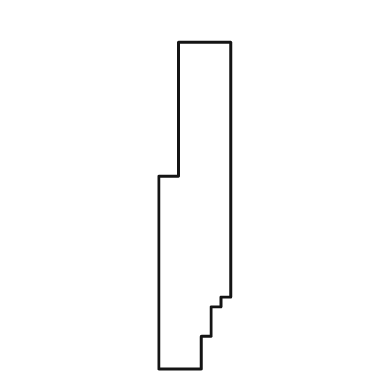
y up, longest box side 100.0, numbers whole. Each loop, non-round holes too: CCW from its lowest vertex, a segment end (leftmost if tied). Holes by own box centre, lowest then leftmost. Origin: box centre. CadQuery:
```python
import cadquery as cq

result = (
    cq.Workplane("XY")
    .moveTo(-11.0, -50.0)
    .lineTo(2.0, -50.0)
    .lineTo(2.0, -40.0)
    .lineTo(5.0, -40.0)
    .lineTo(5.0, -31.0)
    .lineTo(8.0, -31.0)
    .lineTo(8.0, -28.0)
    .lineTo(11.0, -28.0)
    .lineTo(11.0, 50.0)
    .lineTo(-5.0, 50.0)
    .lineTo(-5.0, 9.0)
    .lineTo(-11.0, 9.0)
    .close()
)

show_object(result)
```